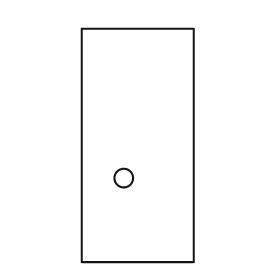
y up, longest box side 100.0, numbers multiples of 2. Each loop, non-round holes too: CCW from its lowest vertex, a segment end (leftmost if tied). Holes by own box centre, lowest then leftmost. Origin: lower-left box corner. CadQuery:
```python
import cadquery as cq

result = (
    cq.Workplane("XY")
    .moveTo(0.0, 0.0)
    .lineTo(48.0, 0.0)
    .lineTo(48.0, 100.0)
    .lineTo(0.0, 100.0)
    .close()
    .moveTo(18.0, 36.0)
    .circle(4.0)
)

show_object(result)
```